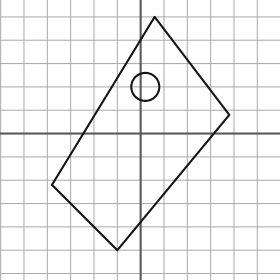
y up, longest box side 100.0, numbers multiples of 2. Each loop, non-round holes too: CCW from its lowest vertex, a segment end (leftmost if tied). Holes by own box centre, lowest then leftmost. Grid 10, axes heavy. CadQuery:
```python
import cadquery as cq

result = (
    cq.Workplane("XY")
    .moveTo(-10.0, -50.0)
    .lineTo(38.0, 8.0)
    .lineTo(6.0, 50.0)
    .lineTo(-38.0, -22.0)
    .close()
    .moveTo(2.0, 20.0)
    .circle(6.0)
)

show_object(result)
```